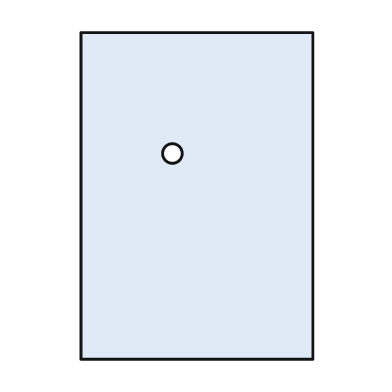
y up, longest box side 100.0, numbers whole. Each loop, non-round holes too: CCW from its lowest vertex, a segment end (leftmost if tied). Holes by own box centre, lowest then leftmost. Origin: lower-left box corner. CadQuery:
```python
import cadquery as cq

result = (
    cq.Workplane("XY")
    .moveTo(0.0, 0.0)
    .lineTo(71.0, 0.0)
    .lineTo(71.0, 100.0)
    .lineTo(0.0, 100.0)
    .close()
    .moveTo(28.0, 63.0)
    .circle(3.0)
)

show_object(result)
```